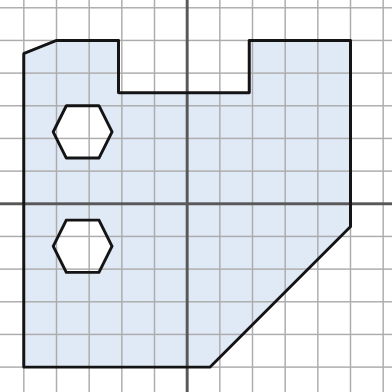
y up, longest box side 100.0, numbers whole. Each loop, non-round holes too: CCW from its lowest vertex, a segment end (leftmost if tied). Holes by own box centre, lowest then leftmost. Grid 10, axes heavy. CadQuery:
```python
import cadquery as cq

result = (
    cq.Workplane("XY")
    .moveTo(-50.0, -50.0)
    .lineTo(7.0, -50.0)
    .lineTo(50.0, -7.0)
    .lineTo(50.0, 50.0)
    .lineTo(19.0, 50.0)
    .lineTo(19.0, 34.0)
    .lineTo(-21.0, 34.0)
    .lineTo(-21.0, 50.0)
    .lineTo(-40.0, 50.0)
    .lineTo(-50.0, 46.0)
    .close()
    .moveTo(-37.0, -21.0)
    .lineTo(-27.0, -21.0)
    .lineTo(-23.0, -13.0)
    .lineTo(-27.0, -5.0)
    .lineTo(-37.0, -5.0)
    .lineTo(-41.0, -13.0)
    .close()
    .moveTo(-37.0, 14.0)
    .lineTo(-27.0, 14.0)
    .lineTo(-23.0, 22.0)
    .lineTo(-27.0, 30.0)
    .lineTo(-37.0, 30.0)
    .lineTo(-41.0, 22.0)
    .close()
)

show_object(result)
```